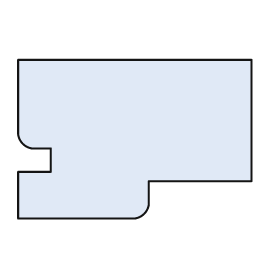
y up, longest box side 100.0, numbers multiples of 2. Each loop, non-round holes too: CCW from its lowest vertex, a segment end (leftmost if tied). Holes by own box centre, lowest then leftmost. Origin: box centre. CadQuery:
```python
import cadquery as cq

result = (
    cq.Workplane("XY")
    .moveTo(-50.0, -34.0)
    .lineTo(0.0, -34.0)
    .threePointArc((4.0, -32.0), (6.0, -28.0))
    .lineTo(6.0, -18.0)
    .lineTo(50.0, -18.0)
    .lineTo(50.0, 34.0)
    .lineTo(-50.0, 34.0)
    .lineTo(-50.0, 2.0)
    .threePointArc((-48.0, -2.0), (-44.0, -4.0))
    .lineTo(-36.0, -4.0)
    .lineTo(-36.0, -14.0)
    .lineTo(-50.0, -14.0)
    .close()
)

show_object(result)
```